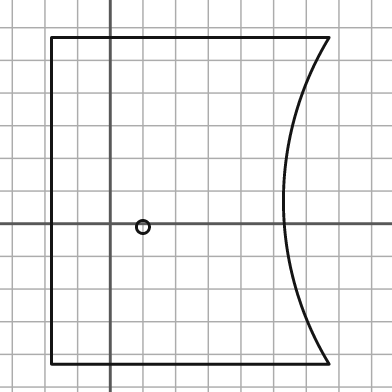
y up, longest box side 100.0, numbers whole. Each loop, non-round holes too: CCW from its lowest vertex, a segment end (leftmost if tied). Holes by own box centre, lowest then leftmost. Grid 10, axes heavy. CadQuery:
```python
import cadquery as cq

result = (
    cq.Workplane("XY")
    .moveTo(-18.0, -43.0)
    .lineTo(67.0, -43.0)
    .threePointArc((53.0, 7.0), (67.0, 57.0))
    .lineTo(-18.0, 57.0)
    .close()
    .moveTo(10.0, -1.0)
    .circle(2.0)
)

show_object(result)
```